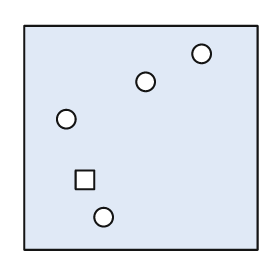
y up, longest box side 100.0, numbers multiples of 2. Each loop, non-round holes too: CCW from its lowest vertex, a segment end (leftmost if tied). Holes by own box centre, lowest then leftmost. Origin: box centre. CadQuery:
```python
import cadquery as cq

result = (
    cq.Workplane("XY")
    .moveTo(-50.0, -48.0)
    .lineTo(50.0, -48.0)
    .lineTo(50.0, 48.0)
    .lineTo(-50.0, 48.0)
    .close()
    .moveTo(-16.0, -34.0)
    .circle(4.0)
    .moveTo(-28.0, -22.0)
    .lineTo(-20.0, -22.0)
    .lineTo(-20.0, -14.0)
    .lineTo(-28.0, -14.0)
    .close()
    .moveTo(-32.0, 8.0)
    .circle(4.0)
    .moveTo(2.0, 24.0)
    .circle(4.0)
    .moveTo(26.0, 36.0)
    .circle(4.0)
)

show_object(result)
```